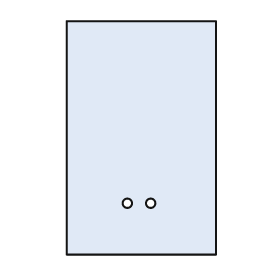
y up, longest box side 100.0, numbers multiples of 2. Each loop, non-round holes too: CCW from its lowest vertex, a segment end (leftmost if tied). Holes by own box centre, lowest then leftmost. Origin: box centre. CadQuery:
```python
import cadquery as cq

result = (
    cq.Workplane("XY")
    .moveTo(-32.0, -50.0)
    .lineTo(32.0, -50.0)
    .lineTo(32.0, 50.0)
    .lineTo(-32.0, 50.0)
    .close()
    .moveTo(-6.0, -28.0)
    .circle(2.0)
    .moveTo(4.0, -28.0)
    .circle(2.0)
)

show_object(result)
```